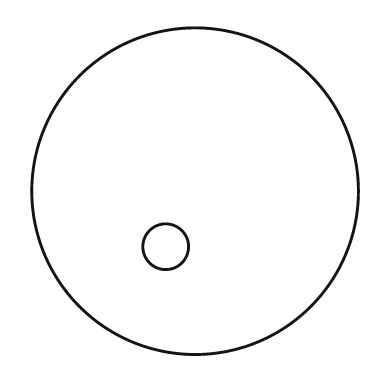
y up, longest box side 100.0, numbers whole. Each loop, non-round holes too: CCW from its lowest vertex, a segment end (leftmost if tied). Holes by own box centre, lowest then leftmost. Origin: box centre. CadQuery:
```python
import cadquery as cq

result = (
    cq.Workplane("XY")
    .moveTo(0.0, 0.0)
    .circle(50.0)
    .moveTo(-9.0, -17.0)
    .circle(7.0)
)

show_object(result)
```